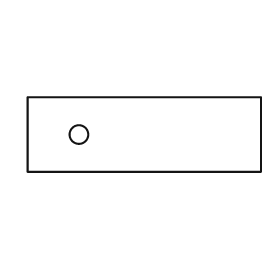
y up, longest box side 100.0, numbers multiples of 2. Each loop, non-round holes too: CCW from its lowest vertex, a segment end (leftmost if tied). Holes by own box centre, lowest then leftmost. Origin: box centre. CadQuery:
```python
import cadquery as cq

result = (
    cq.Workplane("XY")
    .moveTo(-50.0, -16.0)
    .lineTo(50.0, -16.0)
    .lineTo(50.0, 16.0)
    .lineTo(-50.0, 16.0)
    .close()
    .moveTo(-28.0, 0.0)
    .circle(4.0)
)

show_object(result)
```